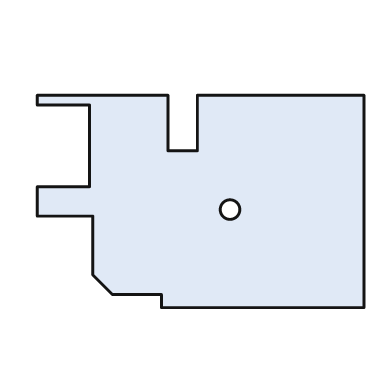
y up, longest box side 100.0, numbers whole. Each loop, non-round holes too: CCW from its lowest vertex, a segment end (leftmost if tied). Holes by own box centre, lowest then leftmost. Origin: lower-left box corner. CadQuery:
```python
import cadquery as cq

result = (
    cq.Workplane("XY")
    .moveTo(38.0, 0.0)
    .lineTo(100.0, 0.0)
    .lineTo(100.0, 65.0)
    .lineTo(49.0, 65.0)
    .lineTo(49.0, 48.0)
    .lineTo(40.0, 48.0)
    .lineTo(40.0, 65.0)
    .lineTo(0.0, 65.0)
    .lineTo(0.0, 62.0)
    .lineTo(16.0, 62.0)
    .lineTo(16.0, 37.0)
    .lineTo(0.0, 37.0)
    .lineTo(0.0, 28.0)
    .lineTo(17.0, 28.0)
    .lineTo(17.0, 10.0)
    .lineTo(23.0, 4.0)
    .lineTo(38.0, 4.0)
    .close()
    .moveTo(59.0, 30.0)
    .circle(3.0)
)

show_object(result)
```